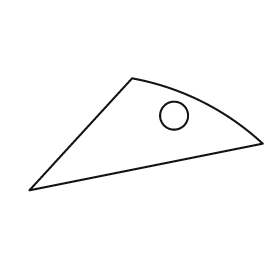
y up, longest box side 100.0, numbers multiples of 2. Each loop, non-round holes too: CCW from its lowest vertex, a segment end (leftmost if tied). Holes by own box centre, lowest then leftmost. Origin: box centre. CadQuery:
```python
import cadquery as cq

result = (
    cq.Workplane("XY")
    .moveTo(-50.0, -24.0)
    .lineTo(50.0, -4.0)
    .threePointArc((24.0, 14.0), (-6.0, 24.0))
    .close()
    .moveTo(12.0, 8.0)
    .circle(6.0)
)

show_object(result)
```